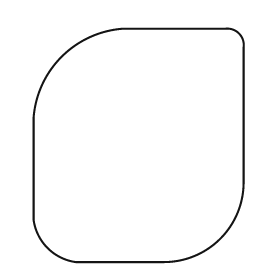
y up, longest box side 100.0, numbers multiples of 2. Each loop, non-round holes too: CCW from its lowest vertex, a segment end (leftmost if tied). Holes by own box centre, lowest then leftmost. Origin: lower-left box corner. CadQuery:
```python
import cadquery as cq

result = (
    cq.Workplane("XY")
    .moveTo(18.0, 0.0)
    .lineTo(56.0, 0.0)
    .threePointArc((80.0, 10.0), (90.0, 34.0))
    .lineTo(90.0, 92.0)
    .threePointArc((88.0, 98.0), (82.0, 100.0))
    .lineTo(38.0, 100.0)
    .threePointArc((12.0, 88.0), (0.0, 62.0))
    .lineTo(0.0, 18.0)
    .threePointArc((6.0, 6.0), (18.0, 0.0))
    .close()
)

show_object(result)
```